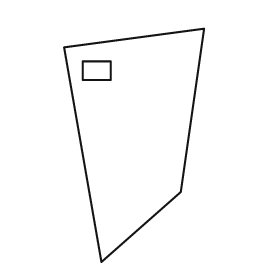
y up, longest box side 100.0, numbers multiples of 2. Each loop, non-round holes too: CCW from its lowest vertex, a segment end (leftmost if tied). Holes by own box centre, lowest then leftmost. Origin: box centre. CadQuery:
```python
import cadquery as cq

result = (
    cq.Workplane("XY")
    .moveTo(-14.0, -50.0)
    .lineTo(20.0, -20.0)
    .lineTo(30.0, 50.0)
    .lineTo(-30.0, 42.0)
    .close()
    .moveTo(-22.0, 28.0)
    .lineTo(-10.0, 28.0)
    .lineTo(-10.0, 36.0)
    .lineTo(-22.0, 36.0)
    .close()
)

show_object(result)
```